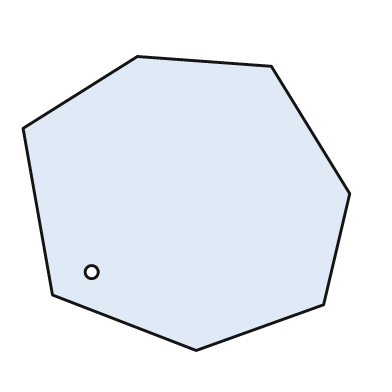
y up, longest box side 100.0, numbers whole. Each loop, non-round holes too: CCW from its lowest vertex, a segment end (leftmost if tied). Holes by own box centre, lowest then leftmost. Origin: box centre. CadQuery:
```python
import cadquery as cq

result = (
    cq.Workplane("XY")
    .moveTo(3.0, -45.0)
    .lineTo(42.0, -31.0)
    .lineTo(50.0, 3.0)
    .lineTo(26.0, 42.0)
    .lineTo(-15.0, 45.0)
    .lineTo(-50.0, 23.0)
    .lineTo(-41.0, -28.0)
    .close()
    .moveTo(-29.0, -21.0)
    .circle(2.0)
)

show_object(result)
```